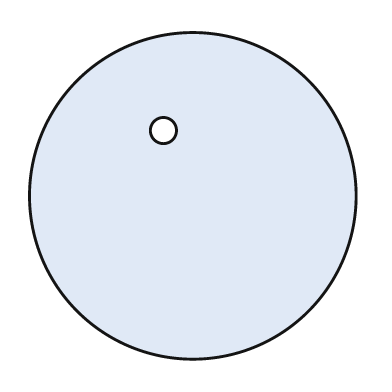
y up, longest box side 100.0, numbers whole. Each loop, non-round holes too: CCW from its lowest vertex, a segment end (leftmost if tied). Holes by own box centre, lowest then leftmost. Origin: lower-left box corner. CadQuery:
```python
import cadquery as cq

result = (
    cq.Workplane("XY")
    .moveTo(50.0, 50.0)
    .circle(50.0)
    .moveTo(41.0, 70.0)
    .circle(4.0)
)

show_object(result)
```